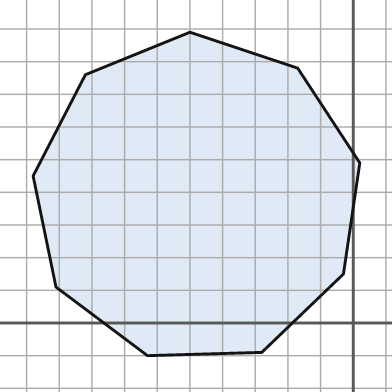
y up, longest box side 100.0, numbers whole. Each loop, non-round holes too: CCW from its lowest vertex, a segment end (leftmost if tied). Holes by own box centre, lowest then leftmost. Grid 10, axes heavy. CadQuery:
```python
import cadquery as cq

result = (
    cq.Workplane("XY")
    .moveTo(-63.0, -10.0)
    .lineTo(-28.0, -9.0)
    .lineTo(-3.0, 15.0)
    .lineTo(2.0, 49.0)
    .lineTo(-17.0, 78.0)
    .lineTo(-50.0, 89.0)
    .lineTo(-82.0, 76.0)
    .lineTo(-98.0, 45.0)
    .lineTo(-91.0, 11.0)
    .close()
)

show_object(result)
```